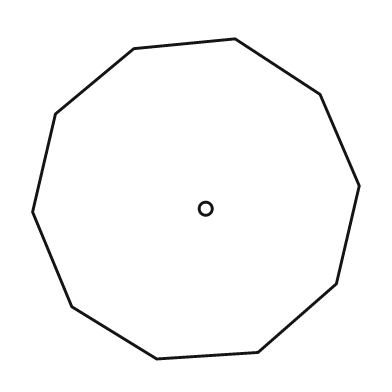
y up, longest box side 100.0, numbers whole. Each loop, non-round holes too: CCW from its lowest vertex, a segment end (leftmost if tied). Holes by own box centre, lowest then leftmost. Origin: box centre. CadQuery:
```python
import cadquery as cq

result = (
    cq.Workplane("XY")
    .moveTo(-12.0, -49.0)
    .lineTo(19.0, -47.0)
    .lineTo(43.0, -26.0)
    .lineTo(50.0, 4.0)
    .lineTo(38.0, 32.0)
    .lineTo(12.0, 49.0)
    .lineTo(-19.0, 46.0)
    .lineTo(-43.0, 26.0)
    .lineTo(-50.0, -4.0)
    .lineTo(-38.0, -33.0)
    .close()
    .moveTo(3.0, -3.0)
    .circle(2.0)
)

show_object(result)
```